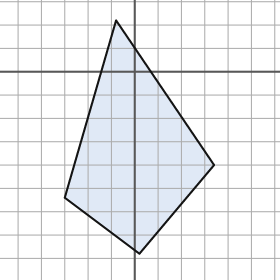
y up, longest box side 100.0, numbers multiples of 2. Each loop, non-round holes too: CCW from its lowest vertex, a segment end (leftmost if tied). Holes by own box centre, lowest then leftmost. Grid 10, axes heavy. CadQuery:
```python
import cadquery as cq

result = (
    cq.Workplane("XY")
    .moveTo(2.0, -78.0)
    .lineTo(34.0, -40.0)
    .lineTo(-8.0, 22.0)
    .lineTo(-30.0, -54.0)
    .close()
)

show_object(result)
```